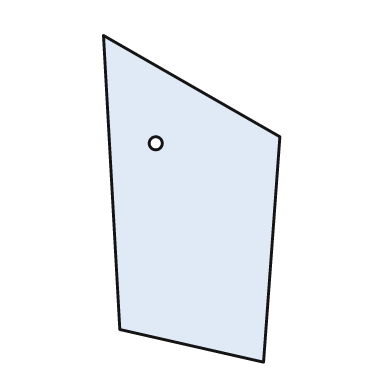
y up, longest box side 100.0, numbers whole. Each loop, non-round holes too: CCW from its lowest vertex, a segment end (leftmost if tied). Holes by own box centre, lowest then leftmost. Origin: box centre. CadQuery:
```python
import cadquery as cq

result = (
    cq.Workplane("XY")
    .moveTo(22.0, -50.0)
    .lineTo(27.0, 19.0)
    .lineTo(-27.0, 50.0)
    .lineTo(-22.0, -40.0)
    .close()
    .moveTo(-11.0, 17.0)
    .circle(2.0)
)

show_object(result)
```